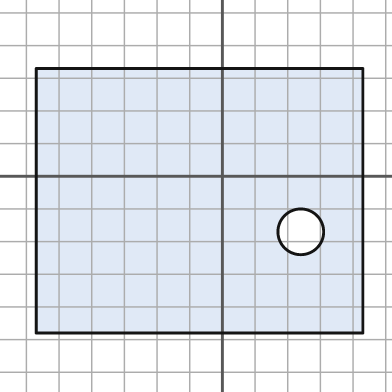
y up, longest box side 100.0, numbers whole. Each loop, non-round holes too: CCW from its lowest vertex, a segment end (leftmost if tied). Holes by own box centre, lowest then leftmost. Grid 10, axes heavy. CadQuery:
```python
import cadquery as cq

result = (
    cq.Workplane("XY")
    .moveTo(-57.0, -48.0)
    .lineTo(43.0, -48.0)
    .lineTo(43.0, 33.0)
    .lineTo(-57.0, 33.0)
    .close()
    .moveTo(24.0, -17.0)
    .circle(7.0)
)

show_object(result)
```